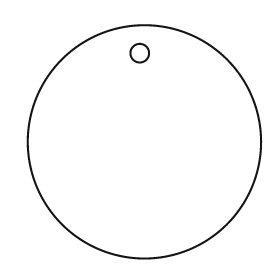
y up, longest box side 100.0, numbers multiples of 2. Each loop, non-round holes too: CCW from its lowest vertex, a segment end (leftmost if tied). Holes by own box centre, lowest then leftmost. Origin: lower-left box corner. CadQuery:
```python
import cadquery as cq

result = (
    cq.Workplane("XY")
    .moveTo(50.0, 50.0)
    .circle(50.0)
    .moveTo(48.0, 88.0)
    .circle(4.0)
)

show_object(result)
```